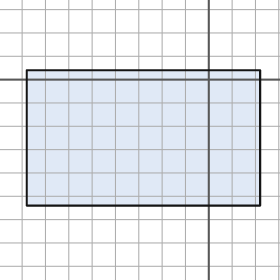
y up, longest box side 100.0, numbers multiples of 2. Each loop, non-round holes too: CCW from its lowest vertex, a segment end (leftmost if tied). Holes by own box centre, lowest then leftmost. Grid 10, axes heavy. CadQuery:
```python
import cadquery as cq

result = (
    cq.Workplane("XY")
    .moveTo(-78.0, -54.0)
    .lineTo(22.0, -54.0)
    .lineTo(22.0, 4.0)
    .lineTo(-78.0, 4.0)
    .close()
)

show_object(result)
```